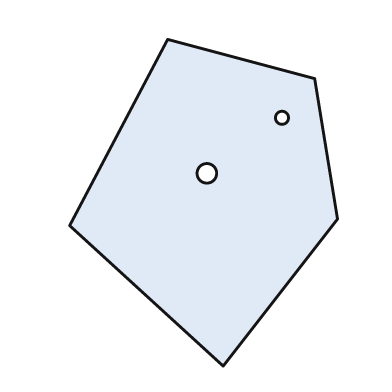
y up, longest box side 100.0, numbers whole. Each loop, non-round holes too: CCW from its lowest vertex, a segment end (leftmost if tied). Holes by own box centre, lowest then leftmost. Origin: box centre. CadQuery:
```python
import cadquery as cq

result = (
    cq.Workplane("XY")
    .moveTo(6.0, -50.0)
    .lineTo(41.0, -5.0)
    .lineTo(34.0, 38.0)
    .lineTo(-11.0, 50.0)
    .lineTo(-41.0, -7.0)
    .close()
    .moveTo(1.0, 9.0)
    .circle(3.0)
    .moveTo(24.0, 26.0)
    .circle(2.0)
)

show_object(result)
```